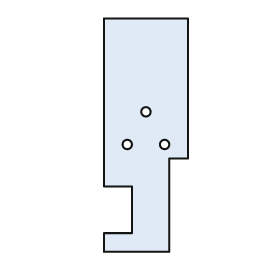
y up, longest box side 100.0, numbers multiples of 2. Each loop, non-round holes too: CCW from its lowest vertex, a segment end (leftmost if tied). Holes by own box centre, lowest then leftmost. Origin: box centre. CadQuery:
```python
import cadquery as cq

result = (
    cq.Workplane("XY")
    .moveTo(-18.0, -50.0)
    .lineTo(10.0, -50.0)
    .lineTo(10.0, -10.0)
    .lineTo(18.0, -10.0)
    .lineTo(18.0, 50.0)
    .lineTo(-18.0, 50.0)
    .lineTo(-18.0, -22.0)
    .lineTo(-6.0, -22.0)
    .lineTo(-6.0, -42.0)
    .lineTo(-18.0, -42.0)
    .close()
    .moveTo(-8.0, -4.0)
    .circle(2.0)
    .moveTo(8.0, -4.0)
    .circle(2.0)
    .moveTo(0.0, 10.0)
    .circle(2.0)
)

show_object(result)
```